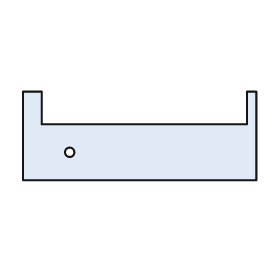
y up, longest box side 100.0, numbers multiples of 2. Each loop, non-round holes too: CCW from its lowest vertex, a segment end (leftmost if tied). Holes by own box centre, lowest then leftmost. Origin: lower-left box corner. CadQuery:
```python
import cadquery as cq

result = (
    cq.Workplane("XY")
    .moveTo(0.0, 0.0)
    .lineTo(100.0, 0.0)
    .lineTo(100.0, 38.0)
    .lineTo(96.0, 38.0)
    .lineTo(96.0, 24.0)
    .lineTo(8.0, 24.0)
    .lineTo(8.0, 38.0)
    .lineTo(0.0, 38.0)
    .close()
    .moveTo(20.0, 12.0)
    .circle(2.0)
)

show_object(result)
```